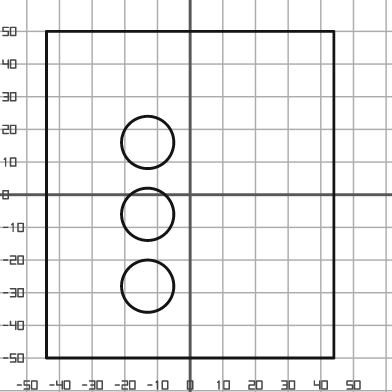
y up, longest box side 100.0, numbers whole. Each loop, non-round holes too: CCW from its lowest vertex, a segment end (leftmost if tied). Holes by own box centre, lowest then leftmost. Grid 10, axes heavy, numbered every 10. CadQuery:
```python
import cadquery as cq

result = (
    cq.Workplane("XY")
    .moveTo(-44.0, -50.0)
    .lineTo(44.0, -50.0)
    .lineTo(44.0, 50.0)
    .lineTo(-44.0, 50.0)
    .close()
    .moveTo(-13.0, -28.0)
    .circle(8.0)
    .moveTo(-13.0, -6.0)
    .circle(8.0)
    .moveTo(-13.0, 16.0)
    .circle(8.0)
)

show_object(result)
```